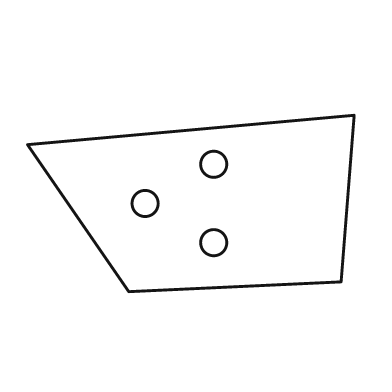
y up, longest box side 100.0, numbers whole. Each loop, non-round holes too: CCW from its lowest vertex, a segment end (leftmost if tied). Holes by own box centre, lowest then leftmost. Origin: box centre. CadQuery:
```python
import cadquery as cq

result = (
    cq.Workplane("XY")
    .moveTo(-19.0, -27.0)
    .lineTo(46.0, -24.0)
    .lineTo(50.0, 27.0)
    .lineTo(-50.0, 18.0)
    .close()
    .moveTo(7.0, -12.0)
    .circle(4.0)
    .moveTo(-14.0, 0.0)
    .circle(4.0)
    .moveTo(7.0, 12.0)
    .circle(4.0)
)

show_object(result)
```